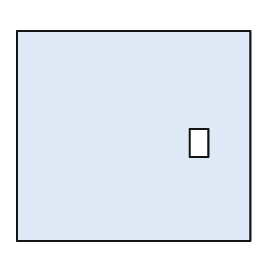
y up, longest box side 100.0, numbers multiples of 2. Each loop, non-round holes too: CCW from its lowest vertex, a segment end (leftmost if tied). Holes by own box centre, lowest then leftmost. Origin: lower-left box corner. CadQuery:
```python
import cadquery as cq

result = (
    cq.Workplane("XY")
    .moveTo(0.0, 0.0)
    .lineTo(100.0, 0.0)
    .lineTo(100.0, 90.0)
    .lineTo(0.0, 90.0)
    .close()
    .moveTo(74.0, 36.0)
    .lineTo(82.0, 36.0)
    .lineTo(82.0, 48.0)
    .lineTo(74.0, 48.0)
    .close()
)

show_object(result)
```